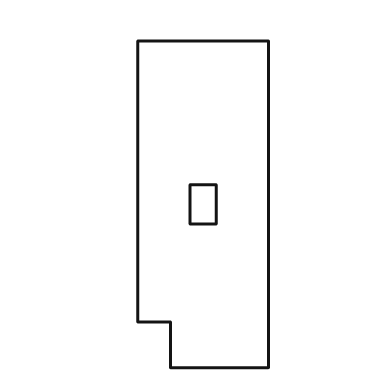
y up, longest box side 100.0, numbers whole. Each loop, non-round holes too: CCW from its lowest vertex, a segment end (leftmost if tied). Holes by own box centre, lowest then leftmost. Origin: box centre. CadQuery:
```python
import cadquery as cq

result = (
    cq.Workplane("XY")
    .moveTo(-10.0, -50.0)
    .lineTo(20.0, -50.0)
    .lineTo(20.0, 50.0)
    .lineTo(-20.0, 50.0)
    .lineTo(-20.0, -36.0)
    .lineTo(-10.0, -36.0)
    .close()
    .moveTo(-4.0, -6.0)
    .lineTo(4.0, -6.0)
    .lineTo(4.0, 6.0)
    .lineTo(-4.0, 6.0)
    .close()
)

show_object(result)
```